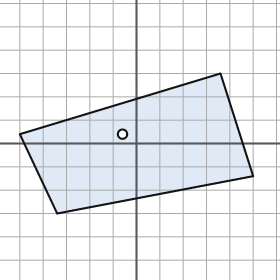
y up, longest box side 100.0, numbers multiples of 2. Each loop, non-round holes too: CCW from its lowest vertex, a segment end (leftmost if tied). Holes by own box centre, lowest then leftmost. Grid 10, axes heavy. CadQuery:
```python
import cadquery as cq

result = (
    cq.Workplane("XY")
    .moveTo(-34.0, -30.0)
    .lineTo(50.0, -14.0)
    .lineTo(36.0, 30.0)
    .lineTo(-50.0, 4.0)
    .close()
    .moveTo(-6.0, 4.0)
    .circle(2.0)
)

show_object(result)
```